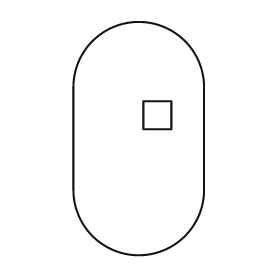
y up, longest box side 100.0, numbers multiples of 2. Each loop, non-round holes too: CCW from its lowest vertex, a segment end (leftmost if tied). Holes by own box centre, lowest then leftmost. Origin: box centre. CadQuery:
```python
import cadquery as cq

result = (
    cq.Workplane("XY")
    .moveTo(-28.0, -22.0)
    .threePointArc((0.0, -50.0), (28.0, -22.0))
    .lineTo(28.0, 22.0)
    .threePointArc((0.0, 50.0), (-28.0, 22.0))
    .close()
    .moveTo(2.0, 4.0)
    .lineTo(14.0, 4.0)
    .lineTo(14.0, 16.0)
    .lineTo(2.0, 16.0)
    .close()
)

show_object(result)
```